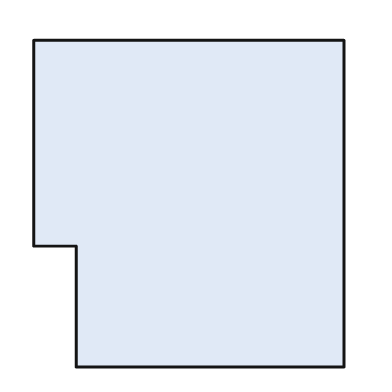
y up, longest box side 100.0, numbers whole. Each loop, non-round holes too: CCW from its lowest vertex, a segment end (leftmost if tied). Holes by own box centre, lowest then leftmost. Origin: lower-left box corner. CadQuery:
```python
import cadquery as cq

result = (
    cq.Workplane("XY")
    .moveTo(13.0, 0.0)
    .lineTo(95.0, 0.0)
    .lineTo(95.0, 100.0)
    .lineTo(0.0, 100.0)
    .lineTo(0.0, 37.0)
    .lineTo(13.0, 37.0)
    .close()
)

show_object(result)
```